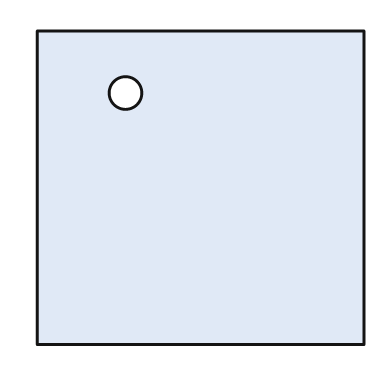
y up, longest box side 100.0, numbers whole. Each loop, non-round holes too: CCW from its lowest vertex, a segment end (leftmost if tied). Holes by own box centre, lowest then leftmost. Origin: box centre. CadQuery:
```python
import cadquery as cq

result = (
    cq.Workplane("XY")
    .moveTo(-50.0, -48.0)
    .lineTo(50.0, -48.0)
    .lineTo(50.0, 48.0)
    .lineTo(-50.0, 48.0)
    .close()
    .moveTo(-23.0, 29.0)
    .circle(5.0)
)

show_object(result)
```